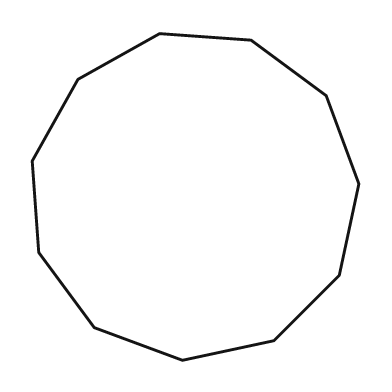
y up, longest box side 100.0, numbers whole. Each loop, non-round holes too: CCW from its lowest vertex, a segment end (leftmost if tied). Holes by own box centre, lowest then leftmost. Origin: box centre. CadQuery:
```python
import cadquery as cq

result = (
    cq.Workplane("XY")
    .moveTo(-4.0, -50.0)
    .lineTo(24.0, -44.0)
    .lineTo(44.0, -24.0)
    .lineTo(50.0, 4.0)
    .lineTo(40.0, 31.0)
    .lineTo(17.0, 48.0)
    .lineTo(-11.0, 50.0)
    .lineTo(-36.0, 36.0)
    .lineTo(-50.0, 11.0)
    .lineTo(-48.0, -17.0)
    .lineTo(-31.0, -40.0)
    .close()
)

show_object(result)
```